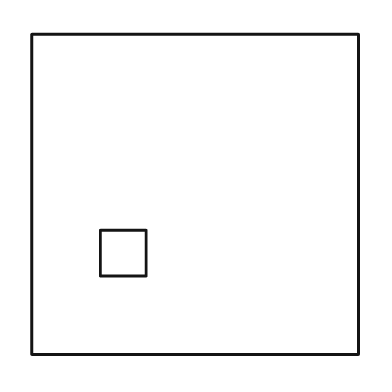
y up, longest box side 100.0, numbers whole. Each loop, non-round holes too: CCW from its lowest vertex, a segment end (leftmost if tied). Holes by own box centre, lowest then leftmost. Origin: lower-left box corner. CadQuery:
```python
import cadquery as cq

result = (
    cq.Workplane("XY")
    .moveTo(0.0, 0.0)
    .lineTo(100.0, 0.0)
    .lineTo(100.0, 98.0)
    .lineTo(0.0, 98.0)
    .close()
    .moveTo(21.0, 24.0)
    .lineTo(35.0, 24.0)
    .lineTo(35.0, 38.0)
    .lineTo(21.0, 38.0)
    .close()
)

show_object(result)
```